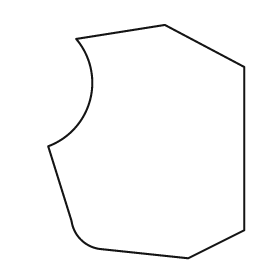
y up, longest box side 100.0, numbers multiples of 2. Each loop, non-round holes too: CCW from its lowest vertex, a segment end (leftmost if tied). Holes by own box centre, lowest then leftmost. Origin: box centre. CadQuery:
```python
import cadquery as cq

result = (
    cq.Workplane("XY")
    .moveTo(18.0, -50.0)
    .lineTo(42.0, -38.0)
    .lineTo(42.0, 32.0)
    .lineTo(8.0, 50.0)
    .lineTo(-30.0, 44.0)
    .threePointArc((-24.0, 18.0), (-42.0, -2.0))
    .lineTo(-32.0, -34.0)
    .threePointArc((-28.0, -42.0), (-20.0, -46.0))
    .close()
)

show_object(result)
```